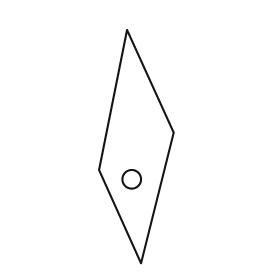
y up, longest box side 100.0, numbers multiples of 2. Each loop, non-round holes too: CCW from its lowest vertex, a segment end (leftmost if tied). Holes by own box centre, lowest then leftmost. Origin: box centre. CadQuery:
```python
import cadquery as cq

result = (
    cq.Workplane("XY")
    .moveTo(2.0, -50.0)
    .lineTo(16.0, 6.0)
    .lineTo(-4.0, 50.0)
    .lineTo(-16.0, -10.0)
    .close()
    .moveTo(-2.0, -14.0)
    .circle(4.0)
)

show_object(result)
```